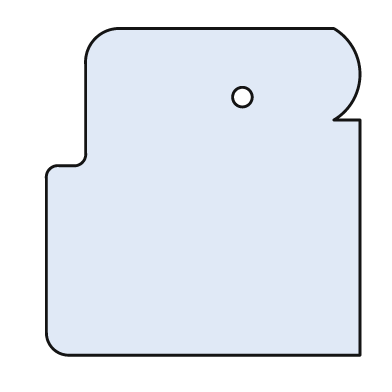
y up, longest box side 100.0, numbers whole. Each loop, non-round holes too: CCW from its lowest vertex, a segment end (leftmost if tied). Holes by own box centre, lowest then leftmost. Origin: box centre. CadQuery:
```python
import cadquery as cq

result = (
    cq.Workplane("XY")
    .moveTo(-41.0, -50.0)
    .lineTo(48.0, -50.0)
    .lineTo(48.0, 22.0)
    .lineTo(40.0, 22.0)
    .threePointArc((48.0, 36.0), (40.0, 50.0))
    .lineTo(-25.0, 50.0)
    .threePointArc((-33.0, 47.0), (-36.0, 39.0))
    .lineTo(-36.0, 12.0)
    .threePointArc((-37.0, 9.0), (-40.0, 8.0))
    .lineTo(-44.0, 8.0)
    .threePointArc((-47.0, 7.0), (-48.0, 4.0))
    .lineTo(-48.0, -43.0)
    .threePointArc((-46.0, -48.0), (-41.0, -50.0))
    .close()
    .moveTo(12.0, 29.0)
    .circle(3.0)
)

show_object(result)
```